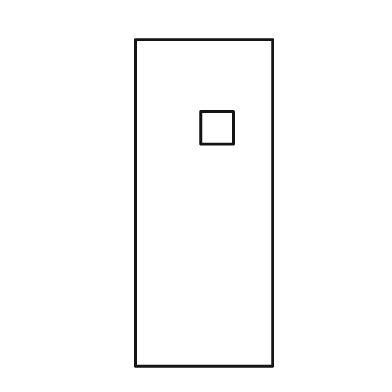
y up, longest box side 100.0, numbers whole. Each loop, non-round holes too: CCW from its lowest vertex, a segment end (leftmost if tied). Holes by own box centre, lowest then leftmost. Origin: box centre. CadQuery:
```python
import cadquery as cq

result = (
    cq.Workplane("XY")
    .moveTo(-21.0, -50.0)
    .lineTo(21.0, -50.0)
    .lineTo(21.0, 50.0)
    .lineTo(-21.0, 50.0)
    .close()
    .moveTo(-1.0, 18.0)
    .lineTo(9.0, 18.0)
    .lineTo(9.0, 28.0)
    .lineTo(-1.0, 28.0)
    .close()
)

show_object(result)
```